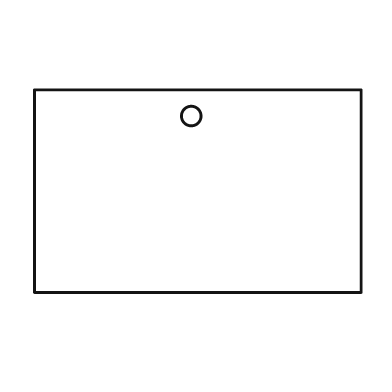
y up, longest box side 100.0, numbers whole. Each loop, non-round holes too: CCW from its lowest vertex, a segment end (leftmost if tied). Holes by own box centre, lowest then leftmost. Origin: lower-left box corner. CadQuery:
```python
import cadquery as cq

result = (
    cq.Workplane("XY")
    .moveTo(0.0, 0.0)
    .lineTo(100.0, 0.0)
    .lineTo(100.0, 62.0)
    .lineTo(0.0, 62.0)
    .close()
    .moveTo(48.0, 54.0)
    .circle(3.0)
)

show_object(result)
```